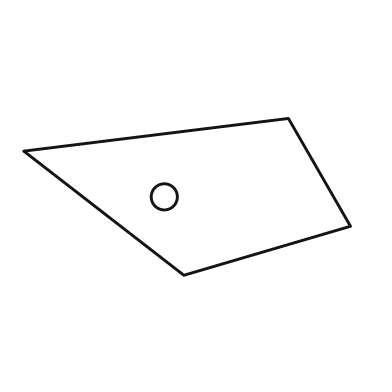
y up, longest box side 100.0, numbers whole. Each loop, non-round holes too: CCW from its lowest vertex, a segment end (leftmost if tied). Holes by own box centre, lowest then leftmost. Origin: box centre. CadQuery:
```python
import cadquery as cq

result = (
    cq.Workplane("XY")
    .moveTo(-1.0, -24.0)
    .lineTo(50.0, -9.0)
    .lineTo(31.0, 24.0)
    .lineTo(-50.0, 14.0)
    .close()
    .moveTo(-7.0, 0.0)
    .circle(4.0)
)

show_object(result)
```